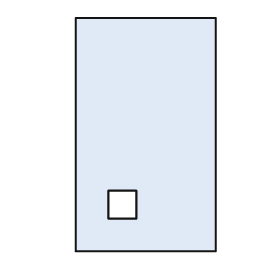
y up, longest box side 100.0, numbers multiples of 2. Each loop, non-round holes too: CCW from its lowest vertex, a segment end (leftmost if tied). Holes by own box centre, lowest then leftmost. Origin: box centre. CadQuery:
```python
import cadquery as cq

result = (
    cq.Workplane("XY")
    .moveTo(-30.0, -50.0)
    .lineTo(30.0, -50.0)
    .lineTo(30.0, 50.0)
    .lineTo(-30.0, 50.0)
    .close()
    .moveTo(-16.0, -36.0)
    .lineTo(-4.0, -36.0)
    .lineTo(-4.0, -24.0)
    .lineTo(-16.0, -24.0)
    .close()
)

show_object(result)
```